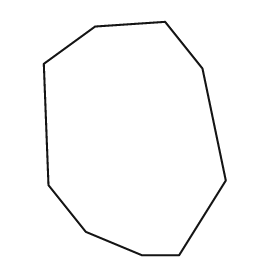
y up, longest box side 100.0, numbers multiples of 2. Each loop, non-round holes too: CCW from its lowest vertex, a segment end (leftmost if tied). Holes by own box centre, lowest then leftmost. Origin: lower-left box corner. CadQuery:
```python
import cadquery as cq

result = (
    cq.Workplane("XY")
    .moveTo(42.0, 0.0)
    .lineTo(58.0, 0.0)
    .lineTo(78.0, 32.0)
    .lineTo(68.0, 80.0)
    .lineTo(52.0, 100.0)
    .lineTo(22.0, 98.0)
    .lineTo(0.0, 82.0)
    .lineTo(2.0, 30.0)
    .lineTo(18.0, 10.0)
    .close()
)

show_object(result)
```